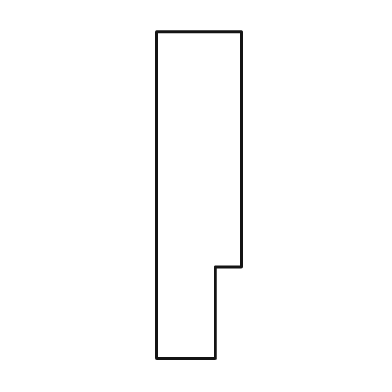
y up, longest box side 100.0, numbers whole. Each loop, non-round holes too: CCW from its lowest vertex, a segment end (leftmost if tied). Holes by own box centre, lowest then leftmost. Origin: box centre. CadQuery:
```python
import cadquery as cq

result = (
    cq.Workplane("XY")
    .moveTo(-13.0, -50.0)
    .lineTo(5.0, -50.0)
    .lineTo(5.0, -22.0)
    .lineTo(13.0, -22.0)
    .lineTo(13.0, 50.0)
    .lineTo(-13.0, 50.0)
    .close()
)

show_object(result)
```